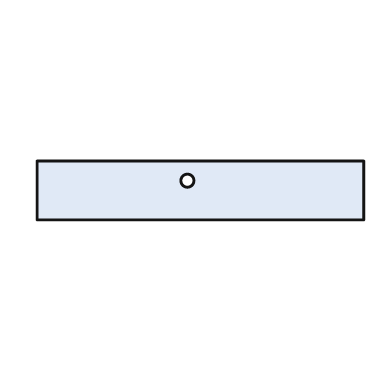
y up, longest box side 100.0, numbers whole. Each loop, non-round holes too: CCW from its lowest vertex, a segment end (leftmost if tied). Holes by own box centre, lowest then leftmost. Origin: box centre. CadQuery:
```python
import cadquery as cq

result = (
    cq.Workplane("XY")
    .moveTo(-50.0, -9.0)
    .lineTo(50.0, -9.0)
    .lineTo(50.0, 9.0)
    .lineTo(-50.0, 9.0)
    .close()
    .moveTo(-4.0, 3.0)
    .circle(2.0)
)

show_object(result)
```